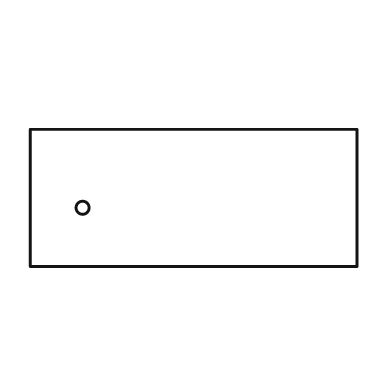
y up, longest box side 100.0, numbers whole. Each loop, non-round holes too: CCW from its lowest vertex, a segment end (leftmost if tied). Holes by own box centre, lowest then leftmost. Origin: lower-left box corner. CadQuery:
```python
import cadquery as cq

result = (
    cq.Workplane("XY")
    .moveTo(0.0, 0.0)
    .lineTo(100.0, 0.0)
    .lineTo(100.0, 42.0)
    .lineTo(0.0, 42.0)
    .close()
    .moveTo(16.0, 18.0)
    .circle(2.0)
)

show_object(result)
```